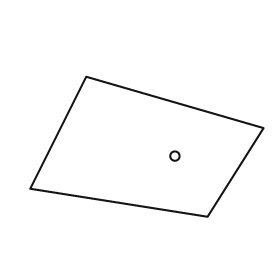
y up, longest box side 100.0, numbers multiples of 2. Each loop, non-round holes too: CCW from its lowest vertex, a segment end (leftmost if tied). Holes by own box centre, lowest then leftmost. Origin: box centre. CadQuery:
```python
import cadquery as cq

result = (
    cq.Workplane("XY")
    .moveTo(26.0, -30.0)
    .lineTo(50.0, 8.0)
    .lineTo(-26.0, 30.0)
    .lineTo(-50.0, -18.0)
    .close()
    .moveTo(12.0, -4.0)
    .circle(2.0)
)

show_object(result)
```